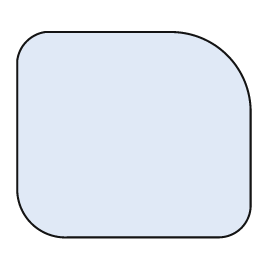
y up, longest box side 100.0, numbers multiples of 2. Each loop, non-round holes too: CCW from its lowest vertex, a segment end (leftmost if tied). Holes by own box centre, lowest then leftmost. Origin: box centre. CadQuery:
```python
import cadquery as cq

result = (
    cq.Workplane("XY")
    .moveTo(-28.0, -44.0)
    .lineTo(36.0, -44.0)
    .threePointArc((46.0, -40.0), (50.0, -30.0))
    .lineTo(50.0, 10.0)
    .threePointArc((40.0, 34.0), (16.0, 44.0))
    .lineTo(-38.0, 44.0)
    .threePointArc((-46.0, 40.0), (-50.0, 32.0))
    .lineTo(-50.0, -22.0)
    .threePointArc((-44.0, -38.0), (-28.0, -44.0))
    .close()
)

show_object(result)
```